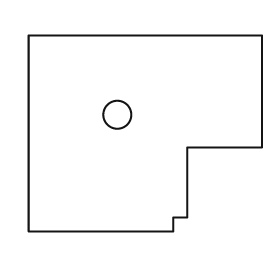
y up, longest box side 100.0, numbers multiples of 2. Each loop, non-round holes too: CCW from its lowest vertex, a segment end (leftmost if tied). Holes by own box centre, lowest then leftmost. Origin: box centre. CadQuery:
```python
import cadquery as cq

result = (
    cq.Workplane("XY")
    .moveTo(-50.0, -42.0)
    .lineTo(12.0, -42.0)
    .lineTo(12.0, -36.0)
    .lineTo(18.0, -36.0)
    .lineTo(18.0, -6.0)
    .lineTo(50.0, -6.0)
    .lineTo(50.0, 42.0)
    .lineTo(-50.0, 42.0)
    .close()
    .moveTo(-12.0, 8.0)
    .circle(6.0)
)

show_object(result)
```